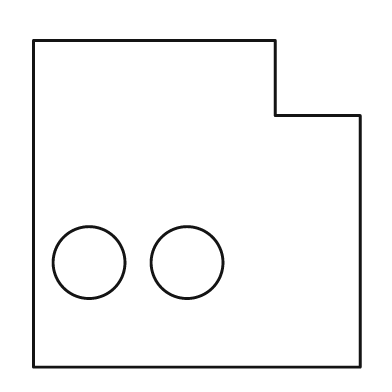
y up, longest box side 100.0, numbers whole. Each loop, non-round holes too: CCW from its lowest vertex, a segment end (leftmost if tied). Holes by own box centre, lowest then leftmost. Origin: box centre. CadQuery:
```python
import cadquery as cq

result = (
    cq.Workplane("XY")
    .moveTo(-50.0, -50.0)
    .lineTo(50.0, -50.0)
    .lineTo(50.0, 27.0)
    .lineTo(24.0, 27.0)
    .lineTo(24.0, 50.0)
    .lineTo(-50.0, 50.0)
    .close()
    .moveTo(-33.0, -18.0)
    .circle(11.0)
    .moveTo(-3.0, -18.0)
    .circle(11.0)
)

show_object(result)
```